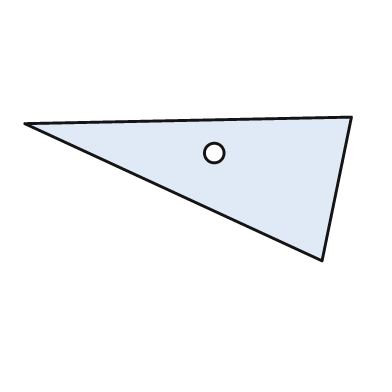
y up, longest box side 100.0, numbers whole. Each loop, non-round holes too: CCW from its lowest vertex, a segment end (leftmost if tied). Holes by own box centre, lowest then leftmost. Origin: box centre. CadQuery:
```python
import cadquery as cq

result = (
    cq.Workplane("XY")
    .moveTo(41.0, -22.0)
    .lineTo(50.0, 22.0)
    .lineTo(-50.0, 20.0)
    .close()
    .moveTo(8.0, 11.0)
    .circle(3.0)
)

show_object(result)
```